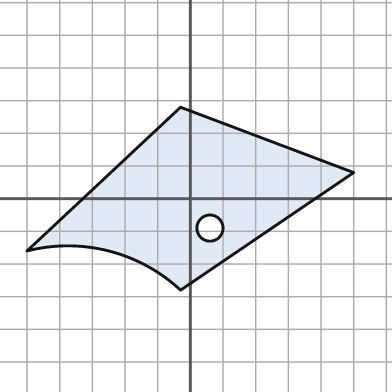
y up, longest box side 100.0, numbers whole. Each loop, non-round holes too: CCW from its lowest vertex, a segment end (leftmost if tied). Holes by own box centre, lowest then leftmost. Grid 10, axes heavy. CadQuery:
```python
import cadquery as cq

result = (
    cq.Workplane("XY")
    .moveTo(-3.0, -28.0)
    .lineTo(50.0, 8.0)
    .lineTo(-3.0, 28.0)
    .lineTo(-50.0, -16.0)
    .threePointArc((-25.0, -16.0), (-3.0, -28.0))
    .close()
    .moveTo(6.0, -9.0)
    .circle(4.0)
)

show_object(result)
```